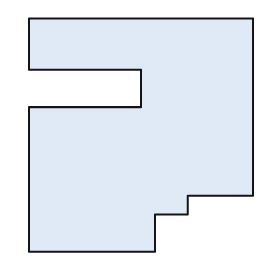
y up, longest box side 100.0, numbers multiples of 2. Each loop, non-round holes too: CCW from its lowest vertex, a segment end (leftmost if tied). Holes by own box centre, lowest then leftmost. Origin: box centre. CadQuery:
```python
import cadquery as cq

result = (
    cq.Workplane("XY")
    .moveTo(-48.0, -50.0)
    .lineTo(6.0, -50.0)
    .lineTo(6.0, -34.0)
    .lineTo(20.0, -34.0)
    .lineTo(20.0, -26.0)
    .lineTo(48.0, -26.0)
    .lineTo(48.0, 50.0)
    .lineTo(-48.0, 50.0)
    .lineTo(-48.0, 28.0)
    .lineTo(0.0, 28.0)
    .lineTo(0.0, 12.0)
    .lineTo(-48.0, 12.0)
    .close()
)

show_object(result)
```